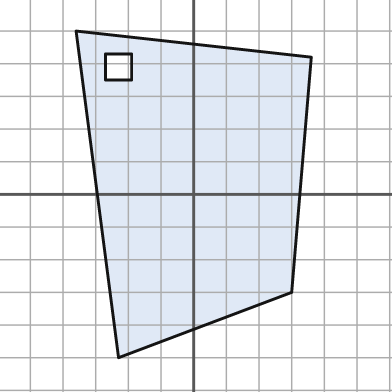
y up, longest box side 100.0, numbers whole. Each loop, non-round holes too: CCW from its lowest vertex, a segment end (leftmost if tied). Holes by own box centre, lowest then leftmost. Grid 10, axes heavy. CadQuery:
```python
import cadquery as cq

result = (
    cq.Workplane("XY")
    .moveTo(-23.0, -50.0)
    .lineTo(30.0, -30.0)
    .lineTo(36.0, 42.0)
    .lineTo(-36.0, 50.0)
    .close()
    .moveTo(-27.0, 35.0)
    .lineTo(-19.0, 35.0)
    .lineTo(-19.0, 43.0)
    .lineTo(-27.0, 43.0)
    .close()
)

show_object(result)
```